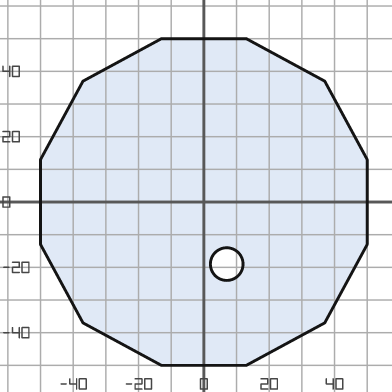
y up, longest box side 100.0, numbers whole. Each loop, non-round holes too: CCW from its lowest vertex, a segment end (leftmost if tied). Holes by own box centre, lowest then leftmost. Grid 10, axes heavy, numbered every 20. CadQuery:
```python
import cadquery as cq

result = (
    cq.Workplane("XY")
    .moveTo(-13.0, -50.0)
    .lineTo(13.0, -50.0)
    .lineTo(37.0, -37.0)
    .lineTo(50.0, -13.0)
    .lineTo(50.0, 13.0)
    .lineTo(37.0, 37.0)
    .lineTo(13.0, 50.0)
    .lineTo(-13.0, 50.0)
    .lineTo(-37.0, 37.0)
    .lineTo(-50.0, 13.0)
    .lineTo(-50.0, -13.0)
    .lineTo(-37.0, -37.0)
    .close()
    .moveTo(7.0, -19.0)
    .circle(5.0)
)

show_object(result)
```